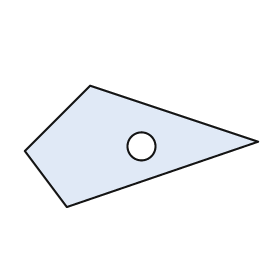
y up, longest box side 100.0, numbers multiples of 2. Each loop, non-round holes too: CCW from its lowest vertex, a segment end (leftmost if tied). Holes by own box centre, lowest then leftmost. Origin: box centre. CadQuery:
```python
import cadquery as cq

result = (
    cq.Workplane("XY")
    .moveTo(-32.0, -26.0)
    .lineTo(50.0, 2.0)
    .lineTo(-22.0, 26.0)
    .lineTo(-50.0, -2.0)
    .close()
    .moveTo(0.0, 0.0)
    .circle(6.0)
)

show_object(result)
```